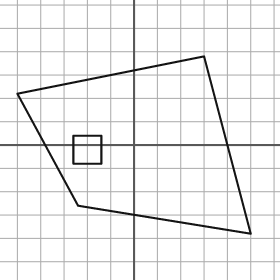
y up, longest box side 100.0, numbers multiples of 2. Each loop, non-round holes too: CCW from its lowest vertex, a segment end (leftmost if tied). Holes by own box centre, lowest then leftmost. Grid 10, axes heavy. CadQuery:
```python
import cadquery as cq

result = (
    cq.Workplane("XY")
    .moveTo(50.0, -38.0)
    .lineTo(30.0, 38.0)
    .lineTo(-50.0, 22.0)
    .lineTo(-24.0, -26.0)
    .close()
    .moveTo(-26.0, -8.0)
    .lineTo(-14.0, -8.0)
    .lineTo(-14.0, 4.0)
    .lineTo(-26.0, 4.0)
    .close()
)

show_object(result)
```